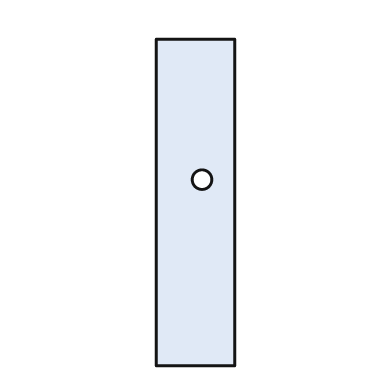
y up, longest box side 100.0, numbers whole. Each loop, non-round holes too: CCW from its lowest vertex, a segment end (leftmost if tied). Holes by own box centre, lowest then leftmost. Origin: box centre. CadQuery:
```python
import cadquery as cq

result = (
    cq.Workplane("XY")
    .moveTo(-12.0, -50.0)
    .lineTo(12.0, -50.0)
    .lineTo(12.0, 50.0)
    .lineTo(-12.0, 50.0)
    .close()
    .moveTo(2.0, 7.0)
    .circle(3.0)
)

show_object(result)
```